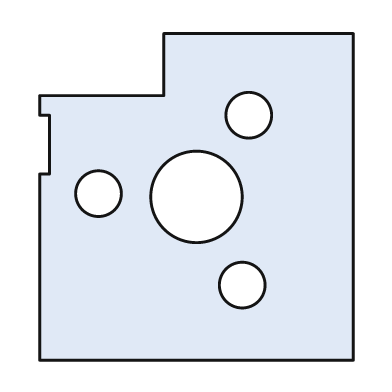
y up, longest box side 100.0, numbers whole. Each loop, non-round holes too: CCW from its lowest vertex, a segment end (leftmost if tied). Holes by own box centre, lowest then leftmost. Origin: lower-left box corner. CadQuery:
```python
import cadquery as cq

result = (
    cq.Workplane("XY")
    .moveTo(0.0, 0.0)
    .lineTo(96.0, 0.0)
    .lineTo(96.0, 100.0)
    .lineTo(38.0, 100.0)
    .lineTo(38.0, 81.0)
    .lineTo(0.0, 81.0)
    .lineTo(0.0, 75.0)
    .lineTo(3.0, 75.0)
    .lineTo(3.0, 57.0)
    .lineTo(0.0, 57.0)
    .close()
    .moveTo(62.0, 23.0)
    .circle(7.0)
    .moveTo(48.0, 50.0)
    .circle(14.0)
    .moveTo(18.0, 51.0)
    .circle(7.0)
    .moveTo(64.0, 75.0)
    .circle(7.0)
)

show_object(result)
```